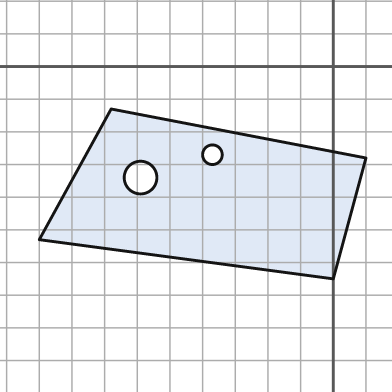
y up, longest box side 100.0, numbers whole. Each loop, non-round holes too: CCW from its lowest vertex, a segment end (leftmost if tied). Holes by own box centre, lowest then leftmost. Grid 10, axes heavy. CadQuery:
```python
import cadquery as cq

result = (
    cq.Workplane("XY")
    .moveTo(0.0, -65.0)
    .lineTo(10.0, -28.0)
    .lineTo(-68.0, -13.0)
    .lineTo(-90.0, -53.0)
    .close()
    .moveTo(-59.0, -34.0)
    .circle(5.0)
    .moveTo(-37.0, -27.0)
    .circle(3.0)
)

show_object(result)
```